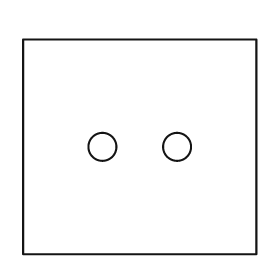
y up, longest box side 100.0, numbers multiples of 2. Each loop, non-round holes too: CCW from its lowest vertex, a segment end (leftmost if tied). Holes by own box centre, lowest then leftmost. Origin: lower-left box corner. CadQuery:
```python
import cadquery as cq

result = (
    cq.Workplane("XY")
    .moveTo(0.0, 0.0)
    .lineTo(100.0, 0.0)
    .lineTo(100.0, 92.0)
    .lineTo(0.0, 92.0)
    .close()
    .moveTo(34.0, 46.0)
    .circle(6.0)
    .moveTo(66.0, 46.0)
    .circle(6.0)
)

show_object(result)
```